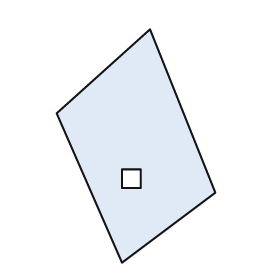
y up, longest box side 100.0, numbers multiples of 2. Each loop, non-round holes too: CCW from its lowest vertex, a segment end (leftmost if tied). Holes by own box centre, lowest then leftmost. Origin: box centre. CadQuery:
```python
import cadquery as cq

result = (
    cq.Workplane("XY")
    .moveTo(-6.0, -50.0)
    .lineTo(34.0, -20.0)
    .lineTo(6.0, 50.0)
    .lineTo(-34.0, 14.0)
    .close()
    .moveTo(-6.0, -18.0)
    .lineTo(2.0, -18.0)
    .lineTo(2.0, -10.0)
    .lineTo(-6.0, -10.0)
    .close()
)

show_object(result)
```